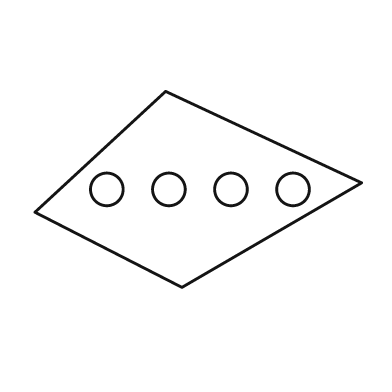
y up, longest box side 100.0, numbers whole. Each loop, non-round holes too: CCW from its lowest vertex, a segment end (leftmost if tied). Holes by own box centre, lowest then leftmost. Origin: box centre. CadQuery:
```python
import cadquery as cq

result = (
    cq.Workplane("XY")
    .moveTo(-5.0, -30.0)
    .lineTo(50.0, 2.0)
    .lineTo(-10.0, 30.0)
    .lineTo(-50.0, -7.0)
    .close()
    .moveTo(-28.0, 0.0)
    .circle(5.0)
    .moveTo(-9.0, 0.0)
    .circle(5.0)
    .moveTo(10.0, 0.0)
    .circle(5.0)
    .moveTo(29.0, 0.0)
    .circle(5.0)
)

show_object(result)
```